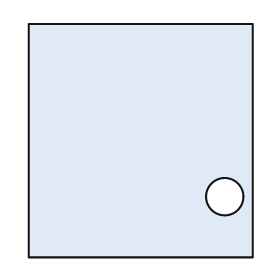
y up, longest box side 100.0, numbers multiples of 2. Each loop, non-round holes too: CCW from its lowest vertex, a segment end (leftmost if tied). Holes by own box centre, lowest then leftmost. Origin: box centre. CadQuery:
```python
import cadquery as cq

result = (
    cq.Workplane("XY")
    .moveTo(-48.0, -50.0)
    .lineTo(48.0, -50.0)
    .lineTo(48.0, 50.0)
    .lineTo(-48.0, 50.0)
    .close()
    .moveTo(36.0, -24.0)
    .circle(8.0)
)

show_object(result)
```